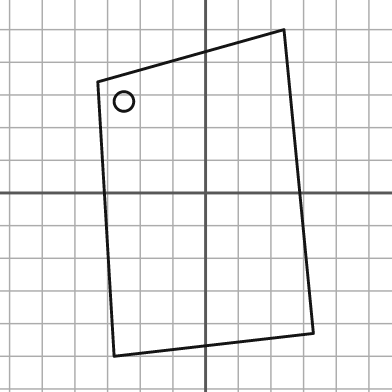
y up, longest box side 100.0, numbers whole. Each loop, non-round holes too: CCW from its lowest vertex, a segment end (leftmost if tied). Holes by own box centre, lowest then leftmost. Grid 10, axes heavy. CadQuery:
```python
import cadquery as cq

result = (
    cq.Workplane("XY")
    .moveTo(-28.0, -50.0)
    .lineTo(33.0, -43.0)
    .lineTo(24.0, 50.0)
    .lineTo(-33.0, 34.0)
    .close()
    .moveTo(-25.0, 28.0)
    .circle(3.0)
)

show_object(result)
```